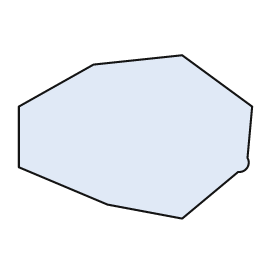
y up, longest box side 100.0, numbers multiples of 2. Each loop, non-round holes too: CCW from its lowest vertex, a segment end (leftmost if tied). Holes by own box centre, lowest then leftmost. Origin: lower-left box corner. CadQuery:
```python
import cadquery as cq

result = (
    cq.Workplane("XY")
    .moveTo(70.0, 0.0)
    .lineTo(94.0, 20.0)
    .threePointArc((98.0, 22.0), (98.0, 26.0))
    .lineTo(100.0, 48.0)
    .lineTo(70.0, 70.0)
    .lineTo(32.0, 66.0)
    .lineTo(0.0, 48.0)
    .lineTo(0.0, 22.0)
    .lineTo(38.0, 6.0)
    .close()
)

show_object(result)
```